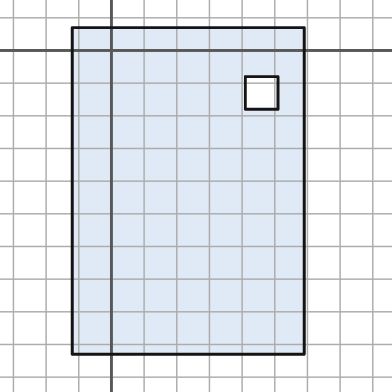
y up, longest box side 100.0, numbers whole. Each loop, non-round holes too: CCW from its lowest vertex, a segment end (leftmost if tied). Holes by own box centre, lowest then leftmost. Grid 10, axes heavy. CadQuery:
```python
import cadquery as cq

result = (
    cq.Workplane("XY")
    .moveTo(-12.0, -93.0)
    .lineTo(59.0, -93.0)
    .lineTo(59.0, 7.0)
    .lineTo(-12.0, 7.0)
    .close()
    .moveTo(41.0, -18.0)
    .lineTo(51.0, -18.0)
    .lineTo(51.0, -8.0)
    .lineTo(41.0, -8.0)
    .close()
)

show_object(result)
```